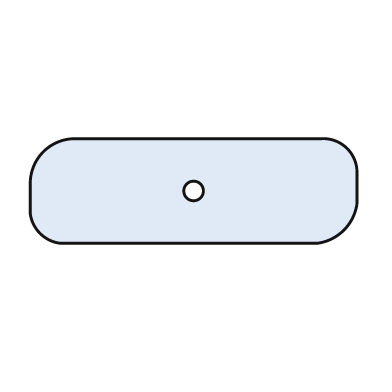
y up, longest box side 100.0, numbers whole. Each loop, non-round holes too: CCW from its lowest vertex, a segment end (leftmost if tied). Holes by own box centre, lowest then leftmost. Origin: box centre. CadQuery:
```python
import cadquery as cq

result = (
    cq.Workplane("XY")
    .moveTo(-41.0, -16.0)
    .lineTo(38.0, -16.0)
    .threePointArc((46.0, -12.0), (50.0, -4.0))
    .lineTo(50.0, 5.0)
    .threePointArc((47.0, 13.0), (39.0, 16.0))
    .lineTo(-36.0, 16.0)
    .threePointArc((-46.0, 12.0), (-50.0, 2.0))
    .lineTo(-50.0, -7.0)
    .threePointArc((-47.0, -13.0), (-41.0, -16.0))
    .close()
    .moveTo(0.0, 0.0)
    .circle(3.0)
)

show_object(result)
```